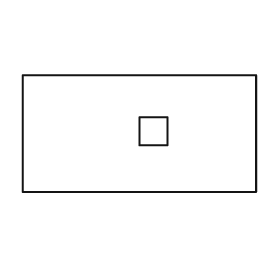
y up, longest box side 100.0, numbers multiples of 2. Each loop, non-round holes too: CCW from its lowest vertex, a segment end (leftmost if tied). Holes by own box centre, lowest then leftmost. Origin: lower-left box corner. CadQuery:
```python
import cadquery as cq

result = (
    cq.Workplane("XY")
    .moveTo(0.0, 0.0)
    .lineTo(100.0, 0.0)
    .lineTo(100.0, 50.0)
    .lineTo(0.0, 50.0)
    .close()
    .moveTo(50.0, 20.0)
    .lineTo(62.0, 20.0)
    .lineTo(62.0, 32.0)
    .lineTo(50.0, 32.0)
    .close()
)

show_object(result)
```